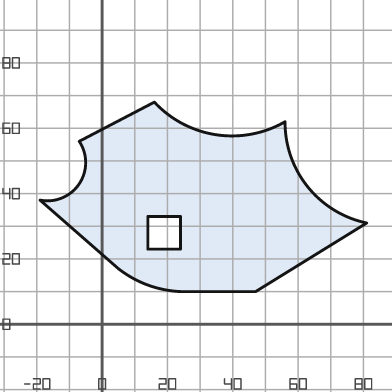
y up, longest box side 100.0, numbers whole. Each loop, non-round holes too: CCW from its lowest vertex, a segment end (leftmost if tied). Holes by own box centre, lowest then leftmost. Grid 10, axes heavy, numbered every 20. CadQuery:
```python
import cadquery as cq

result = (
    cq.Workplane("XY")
    .moveTo(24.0, 10.0)
    .lineTo(47.0, 10.0)
    .lineTo(81.0, 31.0)
    .threePointArc((63.0, 42.0), (56.0, 62.0))
    .threePointArc((35.0, 58.0), (16.0, 68.0))
    .lineTo(-7.0, 56.0)
    .threePointArc((-7.0, 43.0), (-19.0, 38.0))
    .lineTo(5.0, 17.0)
    .threePointArc((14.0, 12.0), (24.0, 10.0))
    .close()
    .moveTo(14.0, 23.0)
    .lineTo(24.0, 23.0)
    .lineTo(24.0, 33.0)
    .lineTo(14.0, 33.0)
    .close()
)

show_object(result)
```